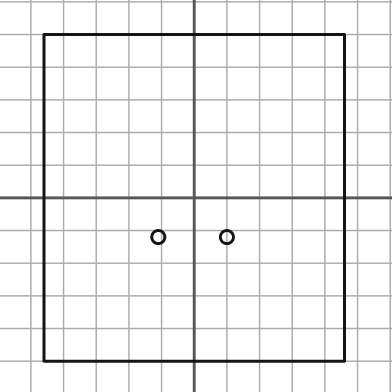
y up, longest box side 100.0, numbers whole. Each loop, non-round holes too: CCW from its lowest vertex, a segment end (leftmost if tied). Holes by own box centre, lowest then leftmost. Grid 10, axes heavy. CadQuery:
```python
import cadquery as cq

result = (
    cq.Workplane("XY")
    .moveTo(-46.0, -50.0)
    .lineTo(46.0, -50.0)
    .lineTo(46.0, 50.0)
    .lineTo(-46.0, 50.0)
    .close()
    .moveTo(-11.0, -12.0)
    .circle(2.0)
    .moveTo(10.0, -12.0)
    .circle(2.0)
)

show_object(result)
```